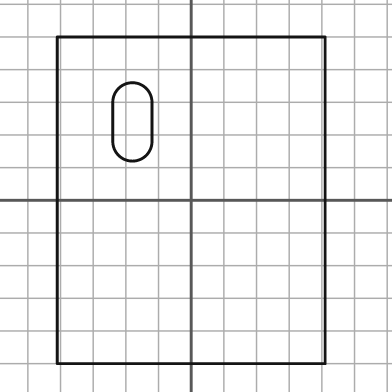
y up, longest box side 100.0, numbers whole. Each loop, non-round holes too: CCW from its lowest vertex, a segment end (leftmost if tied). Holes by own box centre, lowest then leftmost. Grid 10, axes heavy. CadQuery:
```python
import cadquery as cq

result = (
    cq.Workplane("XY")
    .moveTo(-41.0, -50.0)
    .lineTo(41.0, -50.0)
    .lineTo(41.0, 50.0)
    .lineTo(-41.0, 50.0)
    .close()
    .moveTo(-24.0, 18.0)
    .threePointArc((-18.0, 12.0), (-12.0, 18.0))
    .lineTo(-12.0, 30.0)
    .threePointArc((-18.0, 36.0), (-24.0, 30.0))
    .close()
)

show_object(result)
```